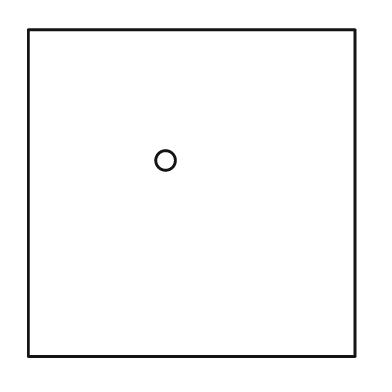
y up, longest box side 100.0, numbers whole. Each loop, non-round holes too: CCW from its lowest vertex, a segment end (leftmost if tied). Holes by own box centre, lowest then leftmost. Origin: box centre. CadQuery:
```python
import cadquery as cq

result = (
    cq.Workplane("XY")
    .moveTo(-50.0, -50.0)
    .lineTo(50.0, -50.0)
    .lineTo(50.0, 50.0)
    .lineTo(-50.0, 50.0)
    .close()
    .moveTo(-8.0, 10.0)
    .circle(3.0)
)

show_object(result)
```